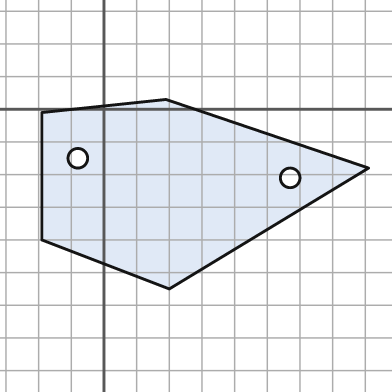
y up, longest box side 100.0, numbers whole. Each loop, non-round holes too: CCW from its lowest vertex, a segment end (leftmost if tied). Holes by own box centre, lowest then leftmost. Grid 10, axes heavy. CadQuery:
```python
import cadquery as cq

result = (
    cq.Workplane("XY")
    .moveTo(20.0, -55.0)
    .lineTo(81.0, -18.0)
    .lineTo(19.0, 3.0)
    .lineTo(-19.0, -1.0)
    .lineTo(-19.0, -40.0)
    .close()
    .moveTo(57.0, -21.0)
    .circle(3.0)
    .moveTo(-8.0, -15.0)
    .circle(3.0)
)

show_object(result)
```